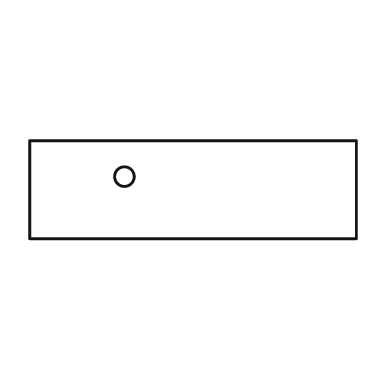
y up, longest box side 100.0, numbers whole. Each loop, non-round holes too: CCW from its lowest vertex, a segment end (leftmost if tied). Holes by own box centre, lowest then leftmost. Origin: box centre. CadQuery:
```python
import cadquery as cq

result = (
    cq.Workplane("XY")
    .moveTo(-50.0, -15.0)
    .lineTo(50.0, -15.0)
    .lineTo(50.0, 15.0)
    .lineTo(-50.0, 15.0)
    .close()
    .moveTo(-21.0, 4.0)
    .circle(3.0)
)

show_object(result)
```